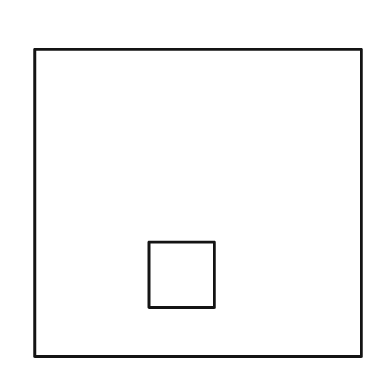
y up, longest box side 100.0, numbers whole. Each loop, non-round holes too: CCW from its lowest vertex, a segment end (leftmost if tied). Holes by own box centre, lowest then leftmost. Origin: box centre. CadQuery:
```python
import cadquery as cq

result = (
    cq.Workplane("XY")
    .moveTo(-50.0, -47.0)
    .lineTo(50.0, -47.0)
    .lineTo(50.0, 47.0)
    .lineTo(-50.0, 47.0)
    .close()
    .moveTo(-15.0, -32.0)
    .lineTo(5.0, -32.0)
    .lineTo(5.0, -12.0)
    .lineTo(-15.0, -12.0)
    .close()
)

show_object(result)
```